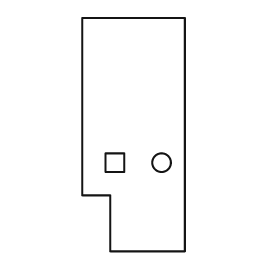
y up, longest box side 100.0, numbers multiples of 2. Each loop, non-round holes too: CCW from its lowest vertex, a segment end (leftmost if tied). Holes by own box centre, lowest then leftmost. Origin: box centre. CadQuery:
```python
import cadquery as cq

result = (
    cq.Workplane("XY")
    .moveTo(-10.0, -50.0)
    .lineTo(22.0, -50.0)
    .lineTo(22.0, 50.0)
    .lineTo(-22.0, 50.0)
    .lineTo(-22.0, -26.0)
    .lineTo(-10.0, -26.0)
    .close()
    .moveTo(-12.0, -16.0)
    .lineTo(-4.0, -16.0)
    .lineTo(-4.0, -8.0)
    .lineTo(-12.0, -8.0)
    .close()
    .moveTo(12.0, -12.0)
    .circle(4.0)
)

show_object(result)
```